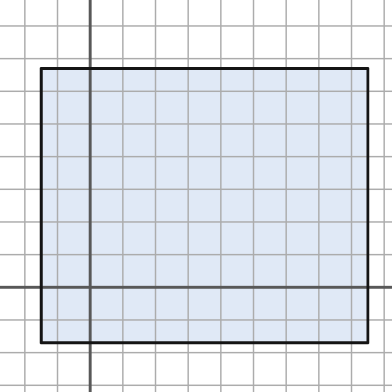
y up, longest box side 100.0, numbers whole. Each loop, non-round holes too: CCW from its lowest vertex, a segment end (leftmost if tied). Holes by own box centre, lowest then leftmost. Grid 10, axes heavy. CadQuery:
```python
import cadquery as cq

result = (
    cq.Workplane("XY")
    .moveTo(-15.0, -17.0)
    .lineTo(85.0, -17.0)
    .lineTo(85.0, 67.0)
    .lineTo(-15.0, 67.0)
    .close()
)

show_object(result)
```